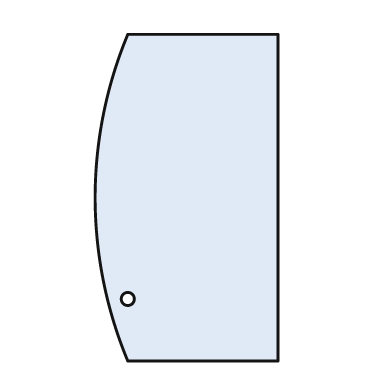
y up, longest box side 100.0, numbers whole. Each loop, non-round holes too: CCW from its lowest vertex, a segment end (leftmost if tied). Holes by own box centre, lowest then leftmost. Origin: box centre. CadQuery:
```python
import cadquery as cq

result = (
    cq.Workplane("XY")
    .moveTo(-18.0, -50.0)
    .lineTo(28.0, -50.0)
    .lineTo(28.0, 50.0)
    .lineTo(-18.0, 50.0)
    .threePointArc((-28.0, 0.0), (-18.0, -50.0))
    .close()
    .moveTo(-18.0, -31.0)
    .circle(2.0)
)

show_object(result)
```